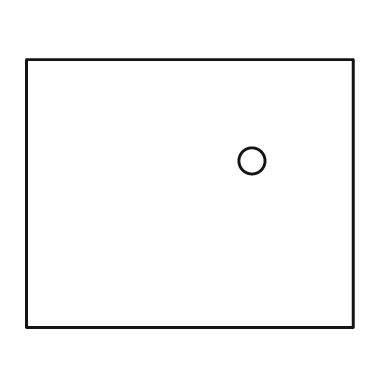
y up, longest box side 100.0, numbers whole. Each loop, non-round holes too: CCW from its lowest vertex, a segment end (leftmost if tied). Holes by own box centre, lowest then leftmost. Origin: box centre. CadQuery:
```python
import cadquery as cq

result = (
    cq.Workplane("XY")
    .moveTo(-50.0, -41.0)
    .lineTo(50.0, -41.0)
    .lineTo(50.0, 41.0)
    .lineTo(-50.0, 41.0)
    .close()
    .moveTo(19.0, 10.0)
    .circle(4.0)
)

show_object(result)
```